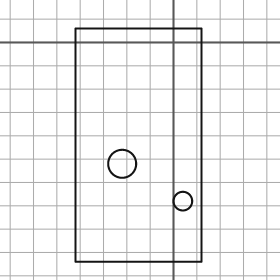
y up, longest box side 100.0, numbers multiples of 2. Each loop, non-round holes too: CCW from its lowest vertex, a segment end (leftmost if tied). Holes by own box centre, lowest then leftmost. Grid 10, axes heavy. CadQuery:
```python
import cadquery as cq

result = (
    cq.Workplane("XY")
    .moveTo(-42.0, -94.0)
    .lineTo(12.0, -94.0)
    .lineTo(12.0, 6.0)
    .lineTo(-42.0, 6.0)
    .close()
    .moveTo(4.0, -68.0)
    .circle(4.0)
    .moveTo(-22.0, -52.0)
    .circle(6.0)
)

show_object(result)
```